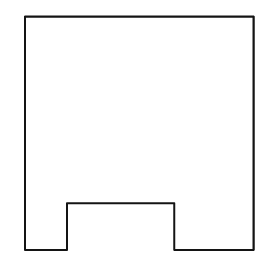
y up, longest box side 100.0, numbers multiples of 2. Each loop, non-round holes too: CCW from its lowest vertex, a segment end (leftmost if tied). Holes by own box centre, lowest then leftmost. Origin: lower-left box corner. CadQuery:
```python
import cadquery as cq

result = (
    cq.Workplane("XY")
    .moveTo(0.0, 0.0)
    .lineTo(18.0, 0.0)
    .lineTo(18.0, 20.0)
    .lineTo(64.0, 20.0)
    .lineTo(64.0, 0.0)
    .lineTo(98.0, 0.0)
    .lineTo(98.0, 100.0)
    .lineTo(0.0, 100.0)
    .close()
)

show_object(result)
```